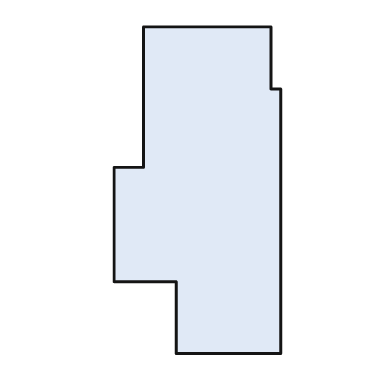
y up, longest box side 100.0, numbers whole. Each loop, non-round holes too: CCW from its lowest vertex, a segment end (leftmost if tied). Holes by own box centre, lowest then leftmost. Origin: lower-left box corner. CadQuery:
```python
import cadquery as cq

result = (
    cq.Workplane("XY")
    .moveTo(19.0, 0.0)
    .lineTo(51.0, 0.0)
    .lineTo(51.0, 81.0)
    .lineTo(48.0, 81.0)
    .lineTo(48.0, 100.0)
    .lineTo(9.0, 100.0)
    .lineTo(9.0, 57.0)
    .lineTo(0.0, 57.0)
    .lineTo(0.0, 22.0)
    .lineTo(19.0, 22.0)
    .close()
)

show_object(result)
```